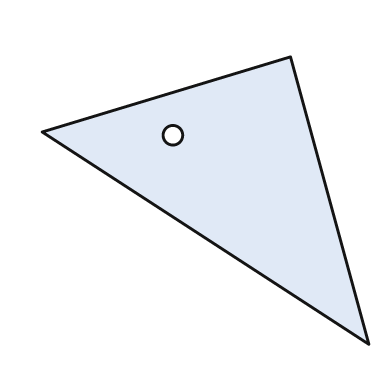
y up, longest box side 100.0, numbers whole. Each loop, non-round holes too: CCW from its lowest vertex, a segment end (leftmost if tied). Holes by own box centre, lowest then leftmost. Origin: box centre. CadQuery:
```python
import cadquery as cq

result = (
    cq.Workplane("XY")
    .moveTo(50.0, -44.0)
    .lineTo(26.0, 44.0)
    .lineTo(-50.0, 21.0)
    .close()
    .moveTo(-10.0, 20.0)
    .circle(3.0)
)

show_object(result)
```